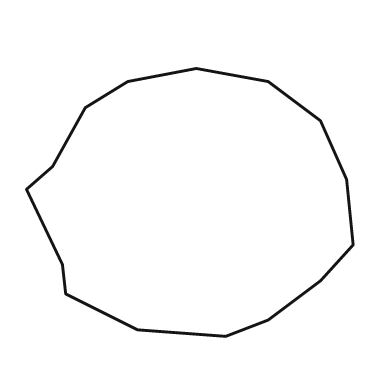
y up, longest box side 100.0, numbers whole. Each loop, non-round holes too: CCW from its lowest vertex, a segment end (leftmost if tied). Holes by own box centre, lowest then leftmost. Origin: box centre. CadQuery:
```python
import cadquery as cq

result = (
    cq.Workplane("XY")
    .moveTo(11.0, -41.0)
    .lineTo(24.0, -36.0)
    .lineTo(40.0, -24.0)
    .lineTo(50.0, -13.0)
    .lineTo(48.0, 7.0)
    .lineTo(40.0, 25.0)
    .lineTo(24.0, 37.0)
    .lineTo(2.0, 41.0)
    .lineTo(-19.0, 37.0)
    .lineTo(-32.0, 29.0)
    .lineTo(-42.0, 11.0)
    .lineTo(-50.0, 4.0)
    .lineTo(-39.0, -19.0)
    .lineTo(-38.0, -28.0)
    .lineTo(-16.0, -39.0)
    .close()
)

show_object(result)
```